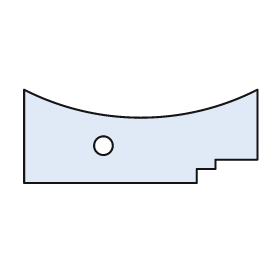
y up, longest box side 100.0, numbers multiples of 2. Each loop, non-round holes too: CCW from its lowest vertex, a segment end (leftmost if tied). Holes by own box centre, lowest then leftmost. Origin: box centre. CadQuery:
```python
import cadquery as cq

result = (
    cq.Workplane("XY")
    .moveTo(-50.0, -20.0)
    .lineTo(24.0, -20.0)
    .lineTo(24.0, -14.0)
    .lineTo(32.0, -14.0)
    .lineTo(32.0, -10.0)
    .lineTo(50.0, -10.0)
    .lineTo(50.0, 20.0)
    .threePointArc((0.0, 8.0), (-50.0, 20.0))
    .close()
    .moveTo(-16.0, -4.0)
    .circle(4.0)
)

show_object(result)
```